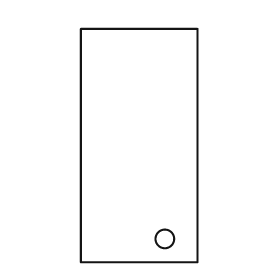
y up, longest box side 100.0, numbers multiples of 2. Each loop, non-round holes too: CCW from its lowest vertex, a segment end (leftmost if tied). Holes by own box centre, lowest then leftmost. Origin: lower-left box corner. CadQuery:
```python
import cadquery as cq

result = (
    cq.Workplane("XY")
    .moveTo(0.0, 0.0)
    .lineTo(50.0, 0.0)
    .lineTo(50.0, 100.0)
    .lineTo(0.0, 100.0)
    .close()
    .moveTo(36.0, 10.0)
    .circle(4.0)
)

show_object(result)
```